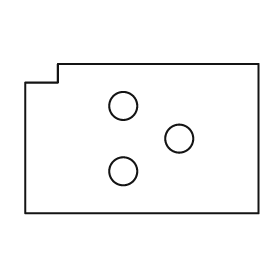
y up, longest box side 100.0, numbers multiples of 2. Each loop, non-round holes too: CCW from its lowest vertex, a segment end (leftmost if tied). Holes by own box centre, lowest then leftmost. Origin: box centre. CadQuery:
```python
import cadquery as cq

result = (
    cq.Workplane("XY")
    .moveTo(-50.0, -32.0)
    .lineTo(50.0, -32.0)
    .lineTo(50.0, 32.0)
    .lineTo(-36.0, 32.0)
    .lineTo(-36.0, 24.0)
    .lineTo(-50.0, 24.0)
    .close()
    .moveTo(-8.0, -14.0)
    .circle(6.0)
    .moveTo(16.0, 0.0)
    .circle(6.0)
    .moveTo(-8.0, 14.0)
    .circle(6.0)
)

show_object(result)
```